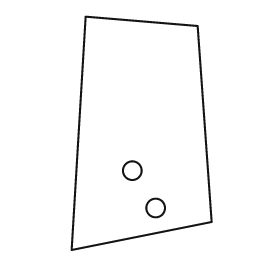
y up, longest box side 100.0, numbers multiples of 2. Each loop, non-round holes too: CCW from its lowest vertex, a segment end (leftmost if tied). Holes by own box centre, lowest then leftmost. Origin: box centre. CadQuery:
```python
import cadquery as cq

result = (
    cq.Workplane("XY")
    .moveTo(-30.0, -50.0)
    .lineTo(30.0, -38.0)
    .lineTo(24.0, 46.0)
    .lineTo(-24.0, 50.0)
    .close()
    .moveTo(6.0, -32.0)
    .circle(4.0)
    .moveTo(-4.0, -16.0)
    .circle(4.0)
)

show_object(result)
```